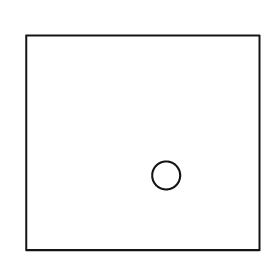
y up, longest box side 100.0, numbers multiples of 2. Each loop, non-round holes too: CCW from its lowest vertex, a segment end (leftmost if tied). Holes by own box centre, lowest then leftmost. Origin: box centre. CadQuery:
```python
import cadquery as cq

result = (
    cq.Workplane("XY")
    .moveTo(-50.0, -46.0)
    .lineTo(50.0, -46.0)
    .lineTo(50.0, 46.0)
    .lineTo(-50.0, 46.0)
    .close()
    .moveTo(10.0, -14.0)
    .circle(6.0)
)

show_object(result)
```